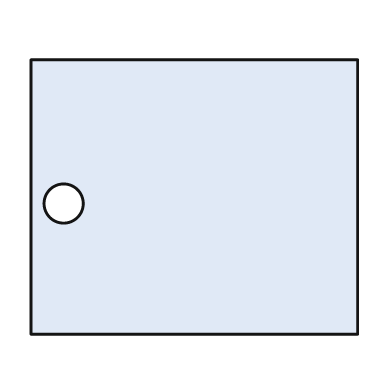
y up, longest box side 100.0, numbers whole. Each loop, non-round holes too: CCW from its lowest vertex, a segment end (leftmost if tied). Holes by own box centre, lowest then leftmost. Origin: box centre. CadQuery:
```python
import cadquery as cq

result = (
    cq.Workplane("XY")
    .moveTo(-50.0, -42.0)
    .lineTo(50.0, -42.0)
    .lineTo(50.0, 42.0)
    .lineTo(-50.0, 42.0)
    .close()
    .moveTo(-40.0, -2.0)
    .circle(6.0)
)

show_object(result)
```